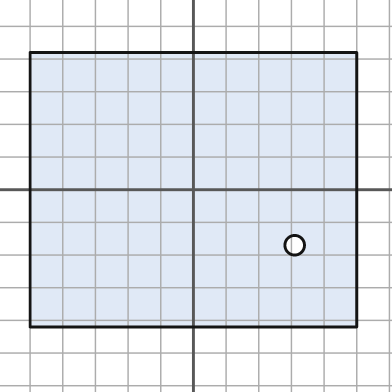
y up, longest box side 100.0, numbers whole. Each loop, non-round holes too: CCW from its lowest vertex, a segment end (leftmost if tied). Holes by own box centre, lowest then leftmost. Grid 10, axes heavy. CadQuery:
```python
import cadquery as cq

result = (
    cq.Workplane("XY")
    .moveTo(-50.0, -42.0)
    .lineTo(50.0, -42.0)
    .lineTo(50.0, 42.0)
    .lineTo(-50.0, 42.0)
    .close()
    .moveTo(31.0, -17.0)
    .circle(3.0)
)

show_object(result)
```